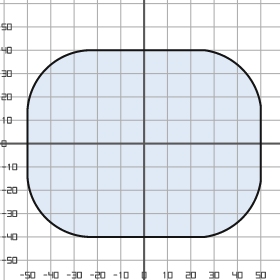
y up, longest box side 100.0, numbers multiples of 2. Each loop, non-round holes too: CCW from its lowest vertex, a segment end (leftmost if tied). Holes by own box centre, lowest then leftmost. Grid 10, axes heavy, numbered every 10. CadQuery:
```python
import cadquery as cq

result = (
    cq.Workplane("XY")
    .moveTo(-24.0, -40.0)
    .lineTo(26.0, -40.0)
    .threePointArc((42.0, -32.0), (50.0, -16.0))
    .lineTo(50.0, 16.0)
    .threePointArc((42.0, 32.0), (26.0, 40.0))
    .lineTo(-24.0, 40.0)
    .threePointArc((-42.0, 32.0), (-50.0, 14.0))
    .lineTo(-50.0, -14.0)
    .threePointArc((-42.0, -32.0), (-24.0, -40.0))
    .close()
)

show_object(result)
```